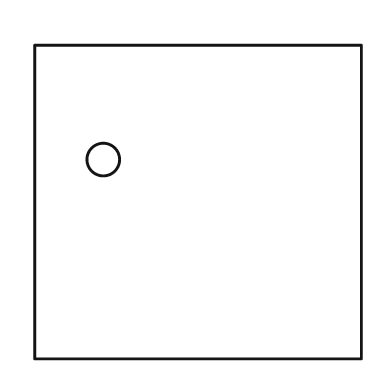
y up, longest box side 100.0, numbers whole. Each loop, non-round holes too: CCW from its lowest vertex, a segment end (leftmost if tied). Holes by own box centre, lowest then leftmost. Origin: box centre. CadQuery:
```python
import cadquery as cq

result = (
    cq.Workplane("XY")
    .moveTo(-50.0, -48.0)
    .lineTo(50.0, -48.0)
    .lineTo(50.0, 48.0)
    .lineTo(-50.0, 48.0)
    .close()
    .moveTo(-29.0, 13.0)
    .circle(5.0)
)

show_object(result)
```